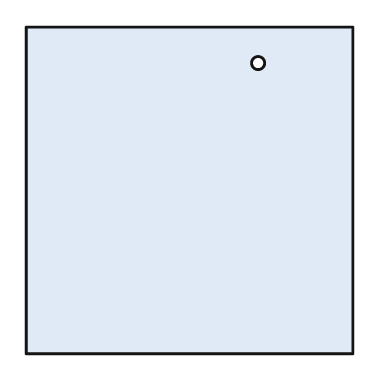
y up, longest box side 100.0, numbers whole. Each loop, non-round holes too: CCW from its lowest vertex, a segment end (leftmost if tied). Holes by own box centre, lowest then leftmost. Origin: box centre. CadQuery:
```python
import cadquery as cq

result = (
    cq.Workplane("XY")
    .moveTo(-50.0, -50.0)
    .lineTo(50.0, -50.0)
    .lineTo(50.0, 50.0)
    .lineTo(-50.0, 50.0)
    .close()
    .moveTo(21.0, 39.0)
    .circle(2.0)
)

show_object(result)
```